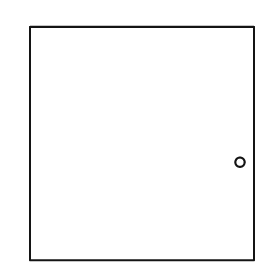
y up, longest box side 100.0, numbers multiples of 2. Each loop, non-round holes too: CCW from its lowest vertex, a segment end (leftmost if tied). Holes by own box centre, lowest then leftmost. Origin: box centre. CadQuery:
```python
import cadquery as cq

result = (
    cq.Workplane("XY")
    .moveTo(-48.0, -50.0)
    .lineTo(48.0, -50.0)
    .lineTo(48.0, 50.0)
    .lineTo(-48.0, 50.0)
    .close()
    .moveTo(42.0, -8.0)
    .circle(2.0)
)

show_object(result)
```